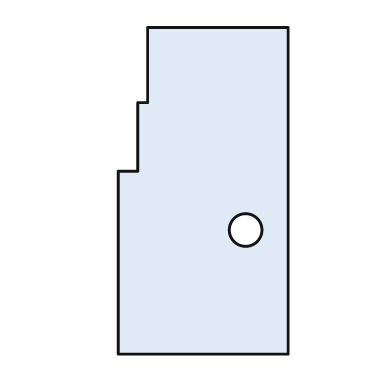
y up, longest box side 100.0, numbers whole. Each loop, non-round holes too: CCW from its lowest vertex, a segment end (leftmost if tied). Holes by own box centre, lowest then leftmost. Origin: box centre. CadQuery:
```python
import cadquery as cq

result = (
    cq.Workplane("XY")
    .moveTo(-26.0, -50.0)
    .lineTo(26.0, -50.0)
    .lineTo(26.0, 50.0)
    .lineTo(-17.0, 50.0)
    .lineTo(-17.0, 27.0)
    .lineTo(-20.0, 27.0)
    .lineTo(-20.0, 6.0)
    .lineTo(-26.0, 6.0)
    .close()
    .moveTo(13.0, -12.0)
    .circle(5.0)
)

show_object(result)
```